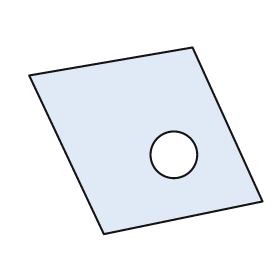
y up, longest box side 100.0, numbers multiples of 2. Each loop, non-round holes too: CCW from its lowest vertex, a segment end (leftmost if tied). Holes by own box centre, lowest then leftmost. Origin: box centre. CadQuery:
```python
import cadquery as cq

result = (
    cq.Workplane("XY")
    .moveTo(-18.0, -40.0)
    .lineTo(50.0, -26.0)
    .lineTo(20.0, 40.0)
    .lineTo(-50.0, 28.0)
    .close()
    .moveTo(12.0, -6.0)
    .circle(10.0)
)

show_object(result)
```